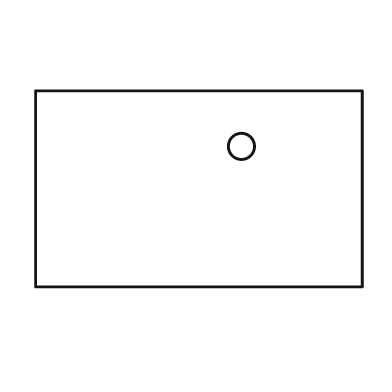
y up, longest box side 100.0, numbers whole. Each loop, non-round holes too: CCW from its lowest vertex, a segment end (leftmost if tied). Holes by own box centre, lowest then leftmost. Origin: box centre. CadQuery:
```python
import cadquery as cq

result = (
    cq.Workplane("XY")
    .moveTo(-50.0, -30.0)
    .lineTo(50.0, -30.0)
    .lineTo(50.0, 30.0)
    .lineTo(-50.0, 30.0)
    .close()
    .moveTo(13.0, 13.0)
    .circle(4.0)
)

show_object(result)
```